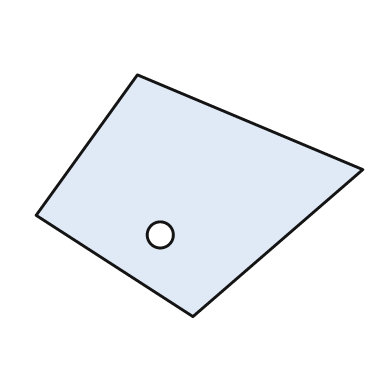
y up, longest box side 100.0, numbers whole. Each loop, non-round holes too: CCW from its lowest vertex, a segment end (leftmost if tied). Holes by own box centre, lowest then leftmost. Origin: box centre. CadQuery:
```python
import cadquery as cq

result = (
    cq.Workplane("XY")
    .moveTo(-2.0, -37.0)
    .lineTo(50.0, 8.0)
    .lineTo(-19.0, 37.0)
    .lineTo(-50.0, -6.0)
    .close()
    .moveTo(-12.0, -12.0)
    .circle(4.0)
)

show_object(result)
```